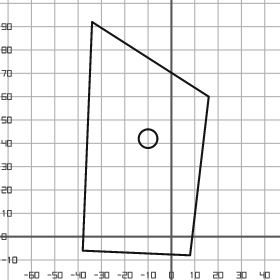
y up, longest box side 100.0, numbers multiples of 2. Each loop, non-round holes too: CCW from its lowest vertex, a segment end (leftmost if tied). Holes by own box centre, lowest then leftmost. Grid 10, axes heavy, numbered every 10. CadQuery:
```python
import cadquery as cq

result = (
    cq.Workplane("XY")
    .moveTo(8.0, -8.0)
    .lineTo(16.0, 60.0)
    .lineTo(-34.0, 92.0)
    .lineTo(-38.0, -6.0)
    .close()
    .moveTo(-10.0, 42.0)
    .circle(4.0)
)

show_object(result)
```